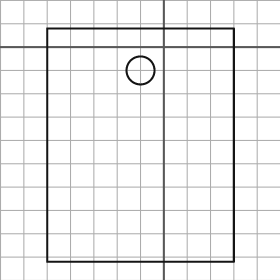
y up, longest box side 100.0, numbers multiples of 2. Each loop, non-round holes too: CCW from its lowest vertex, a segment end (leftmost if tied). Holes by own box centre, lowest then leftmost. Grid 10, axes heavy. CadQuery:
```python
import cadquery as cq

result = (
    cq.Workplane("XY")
    .moveTo(-50.0, -92.0)
    .lineTo(30.0, -92.0)
    .lineTo(30.0, 8.0)
    .lineTo(-50.0, 8.0)
    .close()
    .moveTo(-10.0, -10.0)
    .circle(6.0)
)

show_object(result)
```